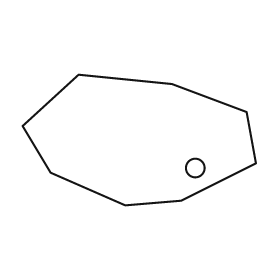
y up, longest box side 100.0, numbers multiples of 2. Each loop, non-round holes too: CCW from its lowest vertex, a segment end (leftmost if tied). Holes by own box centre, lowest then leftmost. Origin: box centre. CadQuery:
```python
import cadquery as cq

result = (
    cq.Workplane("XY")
    .moveTo(-6.0, -28.0)
    .lineTo(18.0, -26.0)
    .lineTo(50.0, -10.0)
    .lineTo(46.0, 12.0)
    .lineTo(14.0, 24.0)
    .lineTo(-26.0, 28.0)
    .lineTo(-50.0, 6.0)
    .lineTo(-38.0, -14.0)
    .close()
    .moveTo(24.0, -12.0)
    .circle(4.0)
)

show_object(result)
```